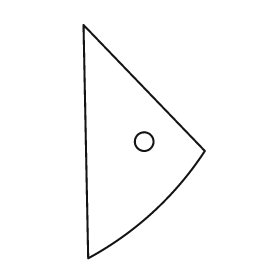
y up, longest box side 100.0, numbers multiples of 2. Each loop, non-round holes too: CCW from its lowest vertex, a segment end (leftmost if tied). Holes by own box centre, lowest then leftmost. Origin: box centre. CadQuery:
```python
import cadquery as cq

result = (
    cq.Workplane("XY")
    .moveTo(-24.0, -50.0)
    .threePointArc((4.0, -30.0), (26.0, -4.0))
    .lineTo(-26.0, 50.0)
    .close()
    .moveTo(0.0, 0.0)
    .circle(4.0)
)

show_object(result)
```